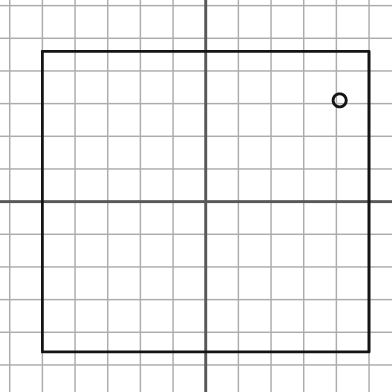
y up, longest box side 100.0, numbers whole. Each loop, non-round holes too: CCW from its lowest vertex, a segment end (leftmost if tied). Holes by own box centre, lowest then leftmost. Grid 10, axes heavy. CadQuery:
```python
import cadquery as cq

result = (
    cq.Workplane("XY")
    .moveTo(-50.0, -46.0)
    .lineTo(50.0, -46.0)
    .lineTo(50.0, 46.0)
    .lineTo(-50.0, 46.0)
    .close()
    .moveTo(41.0, 31.0)
    .circle(2.0)
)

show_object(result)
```